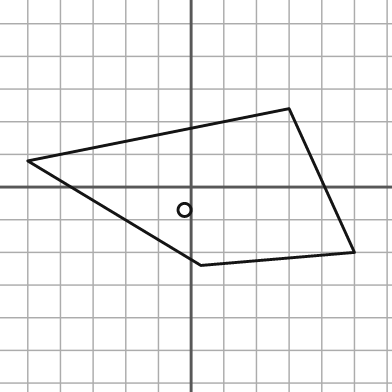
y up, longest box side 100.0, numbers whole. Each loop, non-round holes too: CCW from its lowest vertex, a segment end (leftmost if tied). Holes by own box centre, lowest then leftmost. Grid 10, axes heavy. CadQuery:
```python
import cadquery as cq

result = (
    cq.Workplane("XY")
    .moveTo(3.0, -24.0)
    .lineTo(50.0, -20.0)
    .lineTo(30.0, 24.0)
    .lineTo(-50.0, 8.0)
    .close()
    .moveTo(-2.0, -7.0)
    .circle(2.0)
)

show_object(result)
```